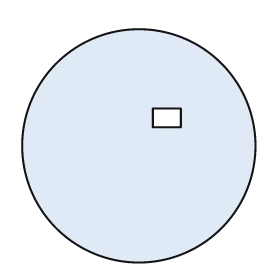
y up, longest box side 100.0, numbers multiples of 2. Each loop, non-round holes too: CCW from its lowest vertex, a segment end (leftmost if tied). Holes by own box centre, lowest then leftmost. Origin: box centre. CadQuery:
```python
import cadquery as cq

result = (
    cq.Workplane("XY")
    .moveTo(0.0, 0.0)
    .circle(50.0)
    .moveTo(6.0, 8.0)
    .lineTo(18.0, 8.0)
    .lineTo(18.0, 16.0)
    .lineTo(6.0, 16.0)
    .close()
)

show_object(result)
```